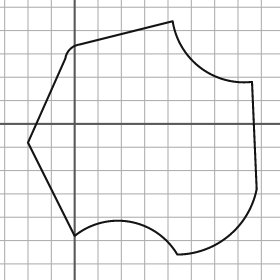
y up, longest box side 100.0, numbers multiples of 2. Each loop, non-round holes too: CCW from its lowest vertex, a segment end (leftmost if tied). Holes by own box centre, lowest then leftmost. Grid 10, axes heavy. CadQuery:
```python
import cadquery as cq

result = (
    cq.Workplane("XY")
    .moveTo(44.0, -56.0)
    .threePointArc((66.0, -48.0), (78.0, -28.0))
    .lineTo(76.0, 18.0)
    .threePointArc((54.0, 24.0), (42.0, 44.0))
    .lineTo(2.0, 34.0)
    .threePointArc((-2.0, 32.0), (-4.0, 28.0))
    .lineTo(-20.0, -8.0)
    .lineTo(0.0, -48.0)
    .threePointArc((24.0, -42.0), (44.0, -56.0))
    .close()
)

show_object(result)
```